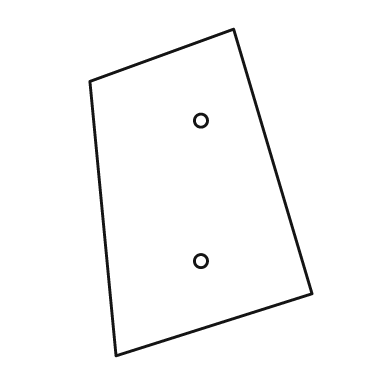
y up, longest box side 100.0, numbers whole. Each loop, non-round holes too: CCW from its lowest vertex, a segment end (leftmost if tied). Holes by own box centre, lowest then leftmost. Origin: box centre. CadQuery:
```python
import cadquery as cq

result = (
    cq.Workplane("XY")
    .moveTo(-26.0, -50.0)
    .lineTo(34.0, -31.0)
    .lineTo(10.0, 50.0)
    .lineTo(-34.0, 34.0)
    .close()
    .moveTo(0.0, -21.0)
    .circle(2.0)
    .moveTo(0.0, 22.0)
    .circle(2.0)
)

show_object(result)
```